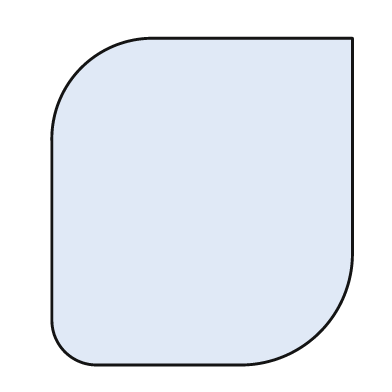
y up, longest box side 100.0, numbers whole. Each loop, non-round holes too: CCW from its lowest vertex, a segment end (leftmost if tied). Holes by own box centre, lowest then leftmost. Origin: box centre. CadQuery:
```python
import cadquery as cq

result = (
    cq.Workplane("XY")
    .moveTo(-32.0, -50.0)
    .lineTo(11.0, -50.0)
    .threePointArc((36.0, -40.0), (46.0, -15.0))
    .lineTo(46.0, 50.0)
    .lineTo(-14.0, 50.0)
    .threePointArc((-37.0, 41.0), (-46.0, 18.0))
    .lineTo(-46.0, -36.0)
    .threePointArc((-42.0, -46.0), (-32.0, -50.0))
    .close()
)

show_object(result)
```